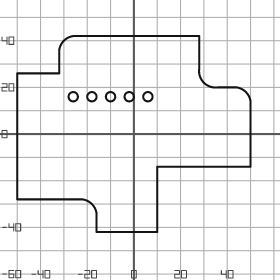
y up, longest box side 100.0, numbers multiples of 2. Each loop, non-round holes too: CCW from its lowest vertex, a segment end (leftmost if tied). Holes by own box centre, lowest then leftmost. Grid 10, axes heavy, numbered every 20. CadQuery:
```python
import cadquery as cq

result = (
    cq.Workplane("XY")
    .moveTo(-16.0, -42.0)
    .lineTo(10.0, -42.0)
    .lineTo(10.0, -14.0)
    .lineTo(50.0, -14.0)
    .lineTo(50.0, 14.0)
    .threePointArc((48.0, 18.0), (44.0, 20.0))
    .lineTo(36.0, 20.0)
    .threePointArc((30.0, 22.0), (28.0, 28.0))
    .lineTo(28.0, 42.0)
    .lineTo(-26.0, 42.0)
    .threePointArc((-30.0, 40.0), (-32.0, 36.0))
    .lineTo(-32.0, 26.0)
    .lineTo(-50.0, 26.0)
    .lineTo(-50.0, -28.0)
    .lineTo(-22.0, -28.0)
    .threePointArc((-18.0, -30.0), (-16.0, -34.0))
    .close()
    .moveTo(-26.0, 16.0)
    .circle(2.0)
    .moveTo(-18.0, 16.0)
    .circle(2.0)
    .moveTo(-10.0, 16.0)
    .circle(2.0)
    .moveTo(-2.0, 16.0)
    .circle(2.0)
    .moveTo(6.0, 16.0)
    .circle(2.0)
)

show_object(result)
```